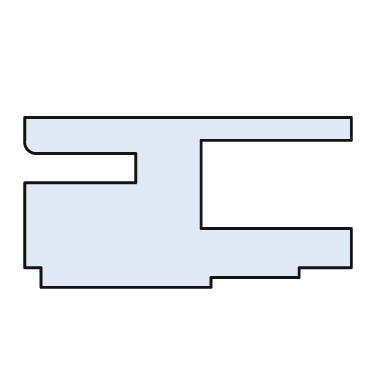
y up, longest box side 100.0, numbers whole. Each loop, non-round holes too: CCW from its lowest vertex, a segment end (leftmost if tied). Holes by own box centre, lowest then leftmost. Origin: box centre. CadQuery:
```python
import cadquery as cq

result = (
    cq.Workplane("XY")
    .moveTo(-45.0, -26.0)
    .lineTo(7.0, -26.0)
    .lineTo(7.0, -23.0)
    .lineTo(34.0, -23.0)
    .lineTo(34.0, -20.0)
    .lineTo(50.0, -20.0)
    .lineTo(50.0, -8.0)
    .lineTo(4.0, -8.0)
    .lineTo(4.0, 19.0)
    .lineTo(50.0, 19.0)
    .lineTo(50.0, 26.0)
    .lineTo(-50.0, 26.0)
    .lineTo(-50.0, 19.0)
    .threePointArc((-49.0, 16.0), (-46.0, 15.0))
    .lineTo(-16.0, 15.0)
    .lineTo(-16.0, 6.0)
    .lineTo(-50.0, 6.0)
    .lineTo(-50.0, -20.0)
    .lineTo(-45.0, -20.0)
    .close()
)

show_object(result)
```